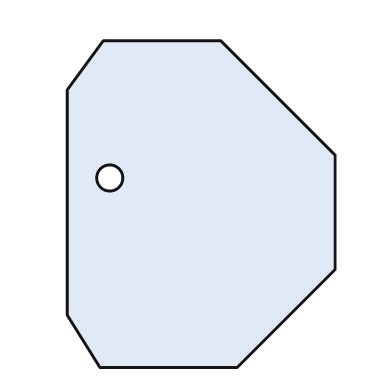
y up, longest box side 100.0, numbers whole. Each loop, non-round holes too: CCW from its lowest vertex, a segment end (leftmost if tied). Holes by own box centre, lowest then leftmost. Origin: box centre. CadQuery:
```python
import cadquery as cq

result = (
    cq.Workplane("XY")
    .moveTo(-31.0, -50.0)
    .lineTo(11.0, -50.0)
    .lineTo(41.0, -20.0)
    .lineTo(41.0, 15.0)
    .lineTo(6.0, 50.0)
    .lineTo(-30.0, 50.0)
    .lineTo(-41.0, 35.0)
    .lineTo(-41.0, -34.0)
    .close()
    .moveTo(-28.0, 8.0)
    .circle(4.0)
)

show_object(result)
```